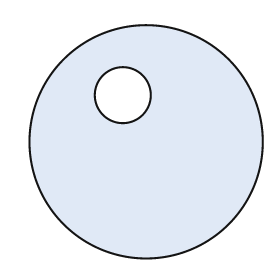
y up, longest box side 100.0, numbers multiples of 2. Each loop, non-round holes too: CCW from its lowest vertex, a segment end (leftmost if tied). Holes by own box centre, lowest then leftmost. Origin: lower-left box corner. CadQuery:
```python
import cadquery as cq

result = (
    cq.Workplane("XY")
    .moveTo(50.0, 50.0)
    .circle(50.0)
    .moveTo(40.0, 70.0)
    .circle(12.0)
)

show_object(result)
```